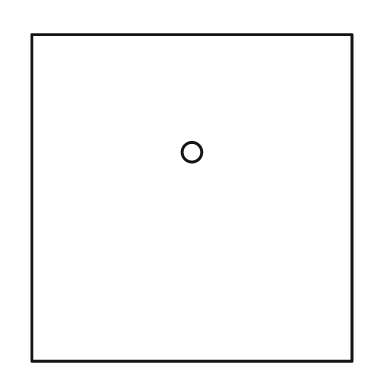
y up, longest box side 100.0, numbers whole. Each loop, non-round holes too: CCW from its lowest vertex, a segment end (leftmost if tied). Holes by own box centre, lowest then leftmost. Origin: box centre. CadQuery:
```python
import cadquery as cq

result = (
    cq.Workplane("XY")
    .moveTo(-49.0, -50.0)
    .lineTo(49.0, -50.0)
    .lineTo(49.0, 50.0)
    .lineTo(-49.0, 50.0)
    .close()
    .moveTo(0.0, 14.0)
    .circle(3.0)
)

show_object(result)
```